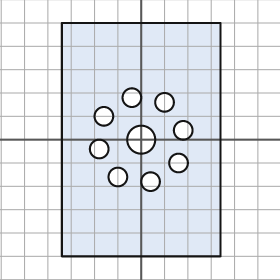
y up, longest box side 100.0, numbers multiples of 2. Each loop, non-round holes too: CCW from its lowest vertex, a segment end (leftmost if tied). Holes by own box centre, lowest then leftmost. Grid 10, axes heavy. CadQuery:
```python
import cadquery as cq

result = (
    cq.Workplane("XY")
    .moveTo(-34.0, -50.0)
    .lineTo(34.0, -50.0)
    .lineTo(34.0, 50.0)
    .lineTo(-34.0, 50.0)
    .close()
    .moveTo(4.0, -18.0)
    .circle(4.0)
    .moveTo(-10.0, -16.0)
    .circle(4.0)
    .moveTo(16.0, -10.0)
    .circle(4.0)
    .moveTo(-18.0, -4.0)
    .circle(4.0)
    .moveTo(0.0, 0.0)
    .circle(6.0)
    .moveTo(18.0, 4.0)
    .circle(4.0)
    .moveTo(-16.0, 10.0)
    .circle(4.0)
    .moveTo(10.0, 16.0)
    .circle(4.0)
    .moveTo(-4.0, 18.0)
    .circle(4.0)
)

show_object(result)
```